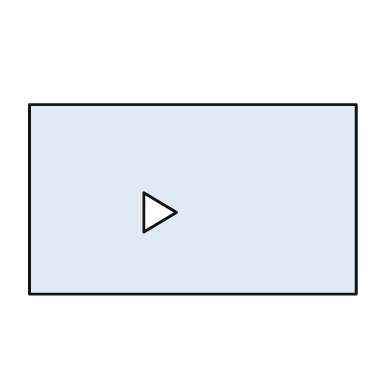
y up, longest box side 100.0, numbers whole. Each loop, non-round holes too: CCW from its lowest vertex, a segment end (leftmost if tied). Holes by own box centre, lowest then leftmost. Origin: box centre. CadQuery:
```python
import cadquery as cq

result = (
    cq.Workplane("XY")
    .moveTo(-50.0, -29.0)
    .lineTo(50.0, -29.0)
    .lineTo(50.0, 29.0)
    .lineTo(-50.0, 29.0)
    .close()
    .moveTo(-15.0, -10.0)
    .lineTo(-5.0, -4.0)
    .lineTo(-15.0, 2.0)
    .close()
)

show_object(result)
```